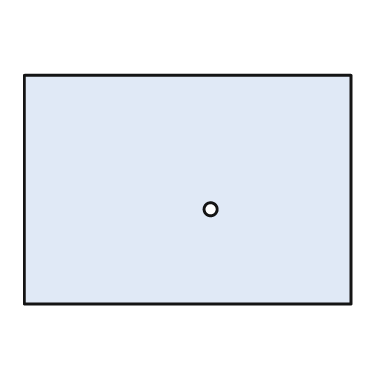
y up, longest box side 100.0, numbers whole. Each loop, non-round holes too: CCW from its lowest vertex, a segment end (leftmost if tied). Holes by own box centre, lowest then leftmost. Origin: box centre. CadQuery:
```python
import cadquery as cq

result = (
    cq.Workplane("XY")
    .moveTo(-50.0, -35.0)
    .lineTo(50.0, -35.0)
    .lineTo(50.0, 35.0)
    .lineTo(-50.0, 35.0)
    .close()
    .moveTo(7.0, -6.0)
    .circle(2.0)
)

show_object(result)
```